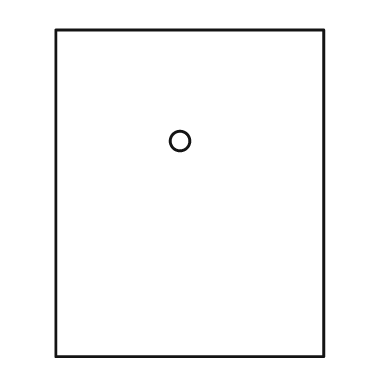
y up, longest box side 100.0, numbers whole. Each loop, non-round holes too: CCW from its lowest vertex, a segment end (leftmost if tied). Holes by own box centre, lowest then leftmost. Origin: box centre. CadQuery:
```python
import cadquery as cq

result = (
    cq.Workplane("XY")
    .moveTo(-41.0, -50.0)
    .lineTo(41.0, -50.0)
    .lineTo(41.0, 50.0)
    .lineTo(-41.0, 50.0)
    .close()
    .moveTo(-3.0, 16.0)
    .circle(3.0)
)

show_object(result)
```